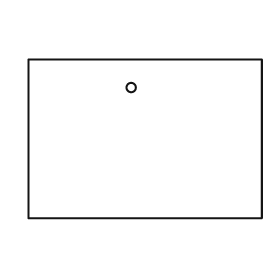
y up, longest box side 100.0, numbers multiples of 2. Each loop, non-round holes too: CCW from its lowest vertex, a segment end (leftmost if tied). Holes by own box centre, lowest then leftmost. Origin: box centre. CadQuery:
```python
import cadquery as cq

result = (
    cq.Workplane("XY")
    .moveTo(-50.0, -34.0)
    .lineTo(50.0, -34.0)
    .lineTo(50.0, 34.0)
    .lineTo(-50.0, 34.0)
    .close()
    .moveTo(-6.0, 22.0)
    .circle(2.0)
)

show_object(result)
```